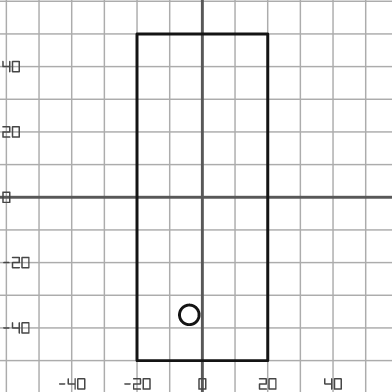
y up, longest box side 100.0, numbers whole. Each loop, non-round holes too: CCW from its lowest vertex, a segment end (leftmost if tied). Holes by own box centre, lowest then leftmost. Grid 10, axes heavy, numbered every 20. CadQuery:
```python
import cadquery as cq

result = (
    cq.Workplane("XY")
    .moveTo(-20.0, -50.0)
    .lineTo(20.0, -50.0)
    .lineTo(20.0, 50.0)
    .lineTo(-20.0, 50.0)
    .close()
    .moveTo(-4.0, -36.0)
    .circle(3.0)
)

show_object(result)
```